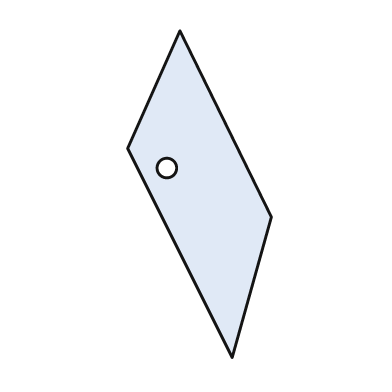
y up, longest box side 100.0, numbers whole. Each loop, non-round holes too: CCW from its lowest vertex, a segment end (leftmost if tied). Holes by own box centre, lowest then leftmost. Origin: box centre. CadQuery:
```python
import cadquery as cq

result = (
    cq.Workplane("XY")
    .moveTo(10.0, -50.0)
    .lineTo(22.0, -7.0)
    .lineTo(-6.0, 50.0)
    .lineTo(-22.0, 14.0)
    .close()
    .moveTo(-10.0, 8.0)
    .circle(3.0)
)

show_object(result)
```